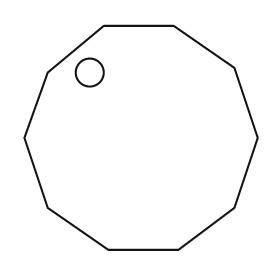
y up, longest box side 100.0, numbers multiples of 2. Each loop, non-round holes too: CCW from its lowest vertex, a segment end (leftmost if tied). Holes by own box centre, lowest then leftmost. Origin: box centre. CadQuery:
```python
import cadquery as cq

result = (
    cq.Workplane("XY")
    .moveTo(-14.0, -48.0)
    .lineTo(16.0, -48.0)
    .lineTo(40.0, -30.0)
    .lineTo(50.0, 0.0)
    .lineTo(40.0, 30.0)
    .lineTo(14.0, 48.0)
    .lineTo(-16.0, 48.0)
    .lineTo(-40.0, 28.0)
    .lineTo(-50.0, 0.0)
    .lineTo(-40.0, -30.0)
    .close()
    .moveTo(-22.0, 28.0)
    .circle(6.0)
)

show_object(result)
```